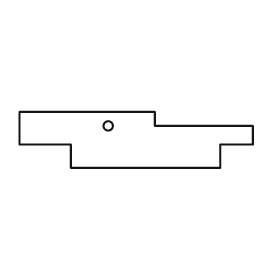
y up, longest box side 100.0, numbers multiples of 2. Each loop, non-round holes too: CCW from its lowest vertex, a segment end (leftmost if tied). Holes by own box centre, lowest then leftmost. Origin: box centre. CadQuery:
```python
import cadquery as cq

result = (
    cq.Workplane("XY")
    .moveTo(-28.0, -12.0)
    .lineTo(36.0, -12.0)
    .lineTo(36.0, -2.0)
    .lineTo(50.0, -2.0)
    .lineTo(50.0, 6.0)
    .lineTo(8.0, 6.0)
    .lineTo(8.0, 12.0)
    .lineTo(-50.0, 12.0)
    .lineTo(-50.0, -2.0)
    .lineTo(-28.0, -2.0)
    .close()
    .moveTo(-12.0, 6.0)
    .circle(2.0)
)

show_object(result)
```